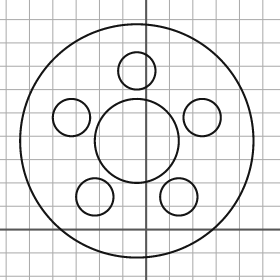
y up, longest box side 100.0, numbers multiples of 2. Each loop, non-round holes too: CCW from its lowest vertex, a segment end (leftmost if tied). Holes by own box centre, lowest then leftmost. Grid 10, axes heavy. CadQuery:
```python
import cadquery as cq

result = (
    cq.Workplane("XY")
    .moveTo(-4.0, 38.0)
    .circle(50.0)
    .moveTo(-22.0, 14.0)
    .circle(8.0)
    .moveTo(14.0, 14.0)
    .circle(8.0)
    .moveTo(-4.0, 38.0)
    .circle(18.0)
    .moveTo(-32.0, 48.0)
    .circle(8.0)
    .moveTo(24.0, 48.0)
    .circle(8.0)
    .moveTo(-4.0, 68.0)
    .circle(8.0)
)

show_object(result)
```